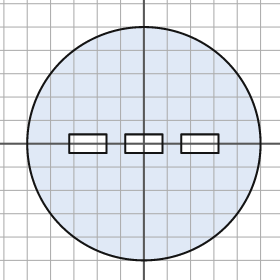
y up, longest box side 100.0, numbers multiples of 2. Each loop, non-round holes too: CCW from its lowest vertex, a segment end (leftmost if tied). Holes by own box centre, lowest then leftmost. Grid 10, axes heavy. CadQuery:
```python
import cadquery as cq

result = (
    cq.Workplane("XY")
    .moveTo(0.0, 0.0)
    .circle(50.0)
    .moveTo(-32.0, -4.0)
    .lineTo(-16.0, -4.0)
    .lineTo(-16.0, 4.0)
    .lineTo(-32.0, 4.0)
    .close()
    .moveTo(-8.0, -4.0)
    .lineTo(8.0, -4.0)
    .lineTo(8.0, 4.0)
    .lineTo(-8.0, 4.0)
    .close()
    .moveTo(16.0, -4.0)
    .lineTo(32.0, -4.0)
    .lineTo(32.0, 4.0)
    .lineTo(16.0, 4.0)
    .close()
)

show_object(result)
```